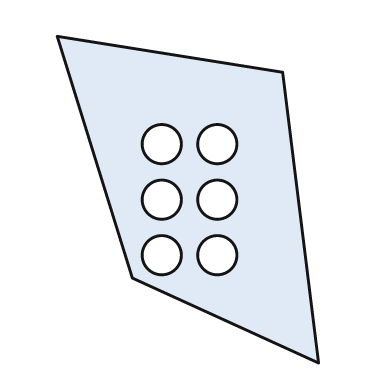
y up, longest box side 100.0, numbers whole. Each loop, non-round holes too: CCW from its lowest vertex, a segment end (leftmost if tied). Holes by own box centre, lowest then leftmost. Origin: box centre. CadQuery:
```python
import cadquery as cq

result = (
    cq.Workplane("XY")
    .moveTo(40.0, -50.0)
    .lineTo(29.0, 39.0)
    .lineTo(-40.0, 50.0)
    .lineTo(-17.0, -24.0)
    .close()
    .moveTo(-8.0, -17.0)
    .circle(6.0)
    .moveTo(9.0, -17.0)
    .circle(6.0)
    .moveTo(-8.0, 0.0)
    .circle(6.0)
    .moveTo(9.0, 0.0)
    .circle(6.0)
    .moveTo(-8.0, 17.0)
    .circle(6.0)
    .moveTo(9.0, 17.0)
    .circle(6.0)
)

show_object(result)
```